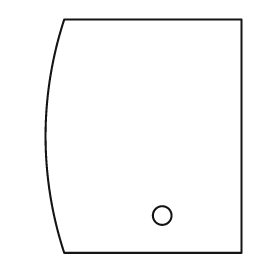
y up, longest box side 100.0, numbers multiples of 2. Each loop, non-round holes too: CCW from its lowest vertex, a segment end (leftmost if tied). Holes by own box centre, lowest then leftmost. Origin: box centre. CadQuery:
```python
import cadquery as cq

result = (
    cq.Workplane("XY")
    .moveTo(-34.0, -50.0)
    .lineTo(42.0, -50.0)
    .lineTo(42.0, 50.0)
    .lineTo(-34.0, 50.0)
    .threePointArc((-42.0, 0.0), (-34.0, -50.0))
    .close()
    .moveTo(8.0, -34.0)
    .circle(4.0)
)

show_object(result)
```